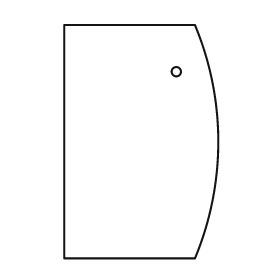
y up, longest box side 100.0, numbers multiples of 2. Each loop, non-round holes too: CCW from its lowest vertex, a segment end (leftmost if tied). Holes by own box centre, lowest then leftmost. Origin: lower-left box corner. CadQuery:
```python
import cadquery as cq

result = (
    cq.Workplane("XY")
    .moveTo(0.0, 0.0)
    .lineTo(56.0, 0.0)
    .threePointArc((66.0, 50.0), (56.0, 100.0))
    .lineTo(0.0, 100.0)
    .close()
    .moveTo(48.0, 80.0)
    .circle(2.0)
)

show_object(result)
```